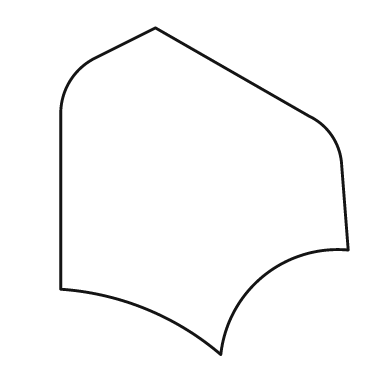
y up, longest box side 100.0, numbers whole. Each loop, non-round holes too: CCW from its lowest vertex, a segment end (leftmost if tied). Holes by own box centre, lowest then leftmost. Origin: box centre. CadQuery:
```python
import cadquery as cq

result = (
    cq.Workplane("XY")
    .moveTo(5.0, -50.0)
    .threePointArc((18.0, -26.0), (44.0, -18.0))
    .lineTo(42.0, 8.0)
    .threePointArc((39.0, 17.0), (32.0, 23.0))
    .lineTo(-15.0, 50.0)
    .lineTo(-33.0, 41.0)
    .threePointArc((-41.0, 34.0), (-44.0, 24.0))
    .lineTo(-44.0, -30.0)
    .threePointArc((-18.0, -36.0), (5.0, -50.0))
    .close()
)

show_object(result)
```